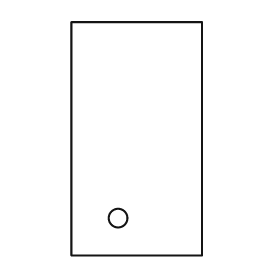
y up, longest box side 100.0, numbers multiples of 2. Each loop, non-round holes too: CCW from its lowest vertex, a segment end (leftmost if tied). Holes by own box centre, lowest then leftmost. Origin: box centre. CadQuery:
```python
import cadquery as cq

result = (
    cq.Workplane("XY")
    .moveTo(-28.0, -50.0)
    .lineTo(28.0, -50.0)
    .lineTo(28.0, 50.0)
    .lineTo(-28.0, 50.0)
    .close()
    .moveTo(-8.0, -34.0)
    .circle(4.0)
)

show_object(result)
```